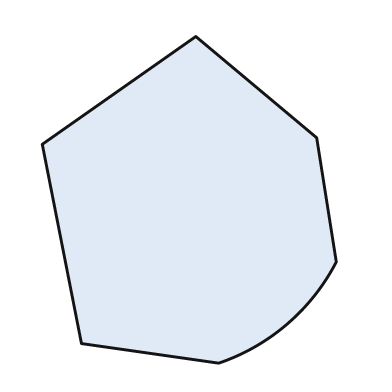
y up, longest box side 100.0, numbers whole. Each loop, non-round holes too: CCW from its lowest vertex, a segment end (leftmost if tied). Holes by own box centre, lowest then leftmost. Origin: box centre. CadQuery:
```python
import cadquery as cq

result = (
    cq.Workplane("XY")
    .moveTo(9.0, -50.0)
    .threePointArc((30.0, -38.0), (45.0, -19.0))
    .lineTo(39.0, 19.0)
    .lineTo(2.0, 50.0)
    .lineTo(-45.0, 17.0)
    .lineTo(-33.0, -44.0)
    .close()
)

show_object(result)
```